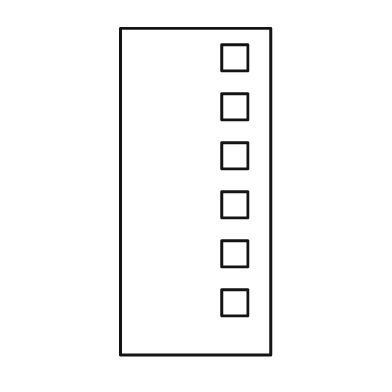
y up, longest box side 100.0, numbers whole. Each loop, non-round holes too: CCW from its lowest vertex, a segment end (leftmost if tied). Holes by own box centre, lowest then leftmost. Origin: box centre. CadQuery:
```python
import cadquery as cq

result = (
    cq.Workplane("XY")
    .moveTo(-23.0, -50.0)
    .lineTo(23.0, -50.0)
    .lineTo(23.0, 50.0)
    .lineTo(-23.0, 50.0)
    .close()
    .moveTo(8.0, -38.0)
    .lineTo(16.0, -38.0)
    .lineTo(16.0, -30.0)
    .lineTo(8.0, -30.0)
    .close()
    .moveTo(8.0, -23.0)
    .lineTo(16.0, -23.0)
    .lineTo(16.0, -15.0)
    .lineTo(8.0, -15.0)
    .close()
    .moveTo(8.0, -8.0)
    .lineTo(16.0, -8.0)
    .lineTo(16.0, 0.0)
    .lineTo(8.0, 0.0)
    .close()
    .moveTo(8.0, 7.0)
    .lineTo(16.0, 7.0)
    .lineTo(16.0, 15.0)
    .lineTo(8.0, 15.0)
    .close()
    .moveTo(8.0, 22.0)
    .lineTo(16.0, 22.0)
    .lineTo(16.0, 30.0)
    .lineTo(8.0, 30.0)
    .close()
    .moveTo(8.0, 37.0)
    .lineTo(16.0, 37.0)
    .lineTo(16.0, 45.0)
    .lineTo(8.0, 45.0)
    .close()
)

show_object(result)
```